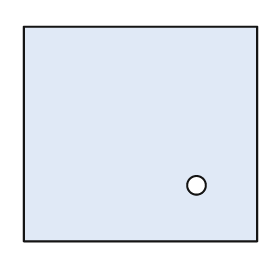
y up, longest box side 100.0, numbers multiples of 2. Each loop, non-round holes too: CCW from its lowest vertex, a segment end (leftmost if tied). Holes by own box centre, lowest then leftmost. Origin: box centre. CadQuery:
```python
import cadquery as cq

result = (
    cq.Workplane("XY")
    .moveTo(-50.0, -46.0)
    .lineTo(50.0, -46.0)
    .lineTo(50.0, 46.0)
    .lineTo(-50.0, 46.0)
    .close()
    .moveTo(24.0, -22.0)
    .circle(4.0)
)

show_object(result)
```